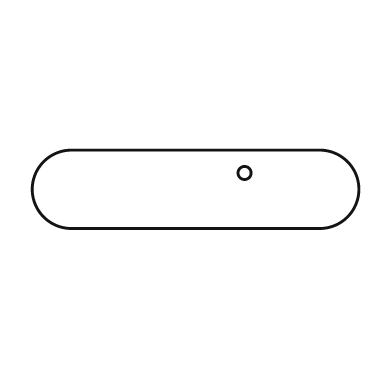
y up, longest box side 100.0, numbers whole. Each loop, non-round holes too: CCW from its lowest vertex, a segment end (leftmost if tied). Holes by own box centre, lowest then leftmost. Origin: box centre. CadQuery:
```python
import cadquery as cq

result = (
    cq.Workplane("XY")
    .moveTo(-38.0, -12.0)
    .lineTo(38.0, -12.0)
    .threePointArc((50.0, 0.0), (38.0, 12.0))
    .lineTo(-38.0, 12.0)
    .threePointArc((-50.0, 0.0), (-38.0, -12.0))
    .close()
    .moveTo(15.0, 5.0)
    .circle(2.0)
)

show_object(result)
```